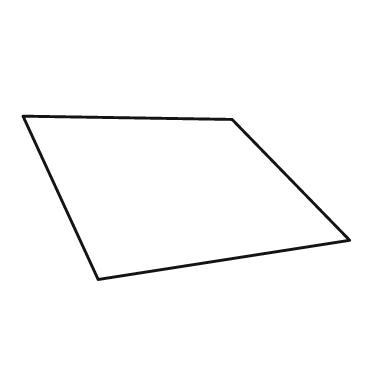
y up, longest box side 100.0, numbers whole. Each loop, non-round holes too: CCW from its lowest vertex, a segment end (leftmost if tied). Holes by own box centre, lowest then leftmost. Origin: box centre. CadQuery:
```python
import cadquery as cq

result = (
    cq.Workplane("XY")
    .moveTo(-27.0, -25.0)
    .lineTo(50.0, -13.0)
    .lineTo(14.0, 24.0)
    .lineTo(-50.0, 25.0)
    .close()
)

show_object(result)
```